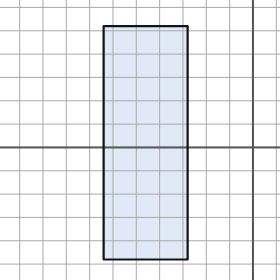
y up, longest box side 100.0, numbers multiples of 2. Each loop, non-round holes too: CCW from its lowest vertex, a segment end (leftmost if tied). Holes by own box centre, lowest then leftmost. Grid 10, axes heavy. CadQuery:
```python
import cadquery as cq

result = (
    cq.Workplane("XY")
    .moveTo(-64.0, -48.0)
    .lineTo(-28.0, -48.0)
    .lineTo(-28.0, 52.0)
    .lineTo(-64.0, 52.0)
    .close()
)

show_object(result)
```